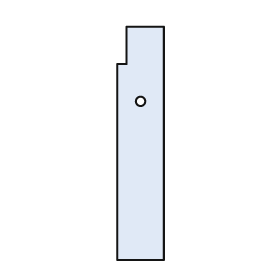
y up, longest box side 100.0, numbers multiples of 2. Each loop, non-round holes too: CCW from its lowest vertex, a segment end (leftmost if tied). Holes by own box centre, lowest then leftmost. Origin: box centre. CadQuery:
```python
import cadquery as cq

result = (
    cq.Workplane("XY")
    .moveTo(-10.0, -50.0)
    .lineTo(10.0, -50.0)
    .lineTo(10.0, 50.0)
    .lineTo(-6.0, 50.0)
    .lineTo(-6.0, 34.0)
    .lineTo(-10.0, 34.0)
    .close()
    .moveTo(0.0, 18.0)
    .circle(2.0)
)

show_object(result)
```